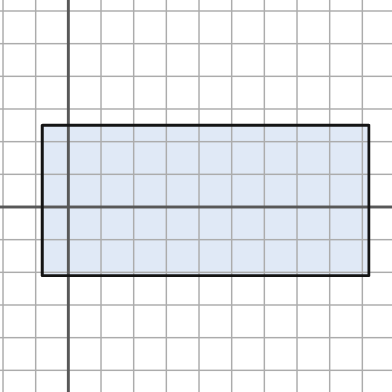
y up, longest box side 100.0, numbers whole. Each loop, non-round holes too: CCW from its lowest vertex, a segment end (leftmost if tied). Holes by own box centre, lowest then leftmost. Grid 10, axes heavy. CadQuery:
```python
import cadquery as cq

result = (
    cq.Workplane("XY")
    .moveTo(-8.0, -21.0)
    .lineTo(92.0, -21.0)
    .lineTo(92.0, 25.0)
    .lineTo(-8.0, 25.0)
    .close()
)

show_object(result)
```